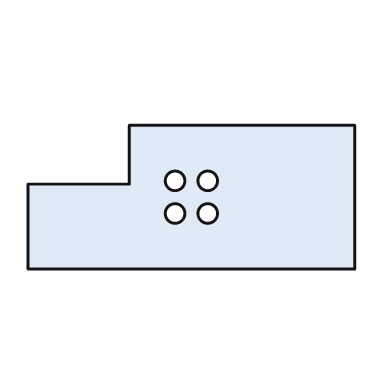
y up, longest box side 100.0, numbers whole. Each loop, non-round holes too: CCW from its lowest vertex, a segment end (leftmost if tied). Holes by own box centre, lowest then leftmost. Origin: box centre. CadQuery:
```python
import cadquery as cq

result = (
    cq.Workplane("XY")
    .moveTo(-50.0, -22.0)
    .lineTo(50.0, -22.0)
    .lineTo(50.0, 22.0)
    .lineTo(-19.0, 22.0)
    .lineTo(-19.0, 4.0)
    .lineTo(-50.0, 4.0)
    .close()
    .moveTo(-5.0, -5.0)
    .circle(3.0)
    .moveTo(5.0, -5.0)
    .circle(3.0)
    .moveTo(-5.0, 5.0)
    .circle(3.0)
    .moveTo(5.0, 5.0)
    .circle(3.0)
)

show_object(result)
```